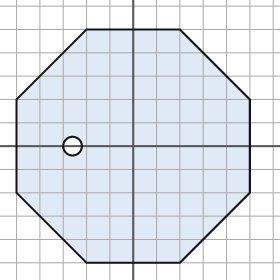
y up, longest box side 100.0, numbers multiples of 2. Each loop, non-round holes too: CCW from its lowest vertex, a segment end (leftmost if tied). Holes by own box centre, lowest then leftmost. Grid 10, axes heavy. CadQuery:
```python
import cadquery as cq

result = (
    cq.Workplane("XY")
    .moveTo(-20.0, -50.0)
    .lineTo(20.0, -50.0)
    .lineTo(50.0, -20.0)
    .lineTo(50.0, 20.0)
    .lineTo(20.0, 50.0)
    .lineTo(-20.0, 50.0)
    .lineTo(-50.0, 20.0)
    .lineTo(-50.0, -20.0)
    .close()
    .moveTo(-26.0, 0.0)
    .circle(4.0)
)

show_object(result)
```